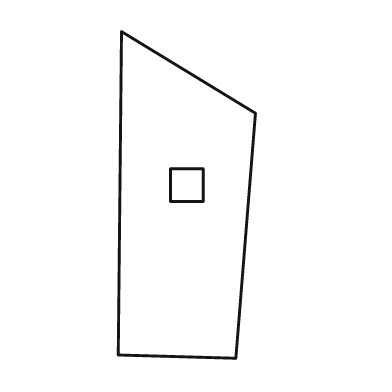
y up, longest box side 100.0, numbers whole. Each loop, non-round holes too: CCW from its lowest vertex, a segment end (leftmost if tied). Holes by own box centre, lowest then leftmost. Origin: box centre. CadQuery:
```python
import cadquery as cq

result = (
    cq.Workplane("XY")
    .moveTo(15.0, -50.0)
    .lineTo(21.0, 25.0)
    .lineTo(-20.0, 50.0)
    .lineTo(-21.0, -49.0)
    .close()
    .moveTo(-5.0, -2.0)
    .lineTo(5.0, -2.0)
    .lineTo(5.0, 8.0)
    .lineTo(-5.0, 8.0)
    .close()
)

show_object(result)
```